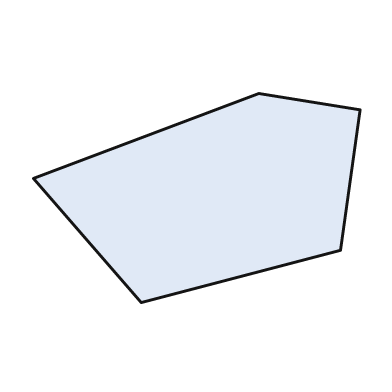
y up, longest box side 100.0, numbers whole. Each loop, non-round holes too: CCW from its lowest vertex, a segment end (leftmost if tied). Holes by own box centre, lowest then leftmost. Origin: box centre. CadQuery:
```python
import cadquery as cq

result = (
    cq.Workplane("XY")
    .moveTo(-17.0, -32.0)
    .lineTo(44.0, -16.0)
    .lineTo(50.0, 27.0)
    .lineTo(19.0, 32.0)
    .lineTo(-50.0, 6.0)
    .close()
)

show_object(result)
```